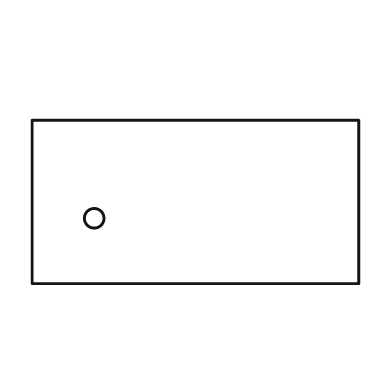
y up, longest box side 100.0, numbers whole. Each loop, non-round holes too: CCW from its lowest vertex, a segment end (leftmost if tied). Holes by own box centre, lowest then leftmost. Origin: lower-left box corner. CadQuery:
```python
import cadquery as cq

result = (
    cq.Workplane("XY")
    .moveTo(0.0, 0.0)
    .lineTo(100.0, 0.0)
    .lineTo(100.0, 50.0)
    .lineTo(0.0, 50.0)
    .close()
    .moveTo(19.0, 20.0)
    .circle(3.0)
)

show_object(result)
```